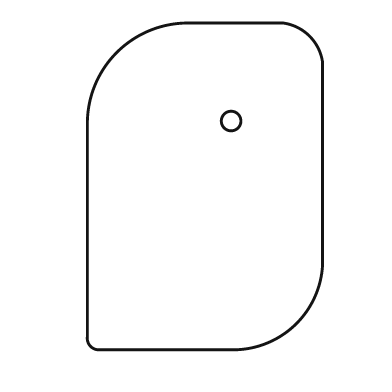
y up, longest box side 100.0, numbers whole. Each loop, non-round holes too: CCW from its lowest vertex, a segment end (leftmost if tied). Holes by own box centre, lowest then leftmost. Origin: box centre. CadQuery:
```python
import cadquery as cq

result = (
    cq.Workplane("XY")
    .moveTo(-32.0, -50.0)
    .lineTo(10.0, -50.0)
    .threePointArc((28.0, -42.0), (36.0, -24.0))
    .lineTo(36.0, 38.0)
    .threePointArc((32.0, 46.0), (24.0, 50.0))
    .lineTo(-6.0, 50.0)
    .threePointArc((-27.0, 41.0), (-36.0, 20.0))
    .lineTo(-36.0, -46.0)
    .threePointArc((-35.0, -49.0), (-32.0, -50.0))
    .close()
    .moveTo(8.0, 20.0)
    .circle(3.0)
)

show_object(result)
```